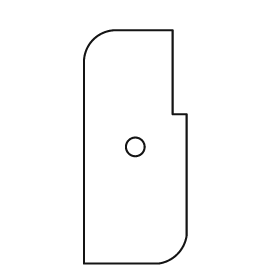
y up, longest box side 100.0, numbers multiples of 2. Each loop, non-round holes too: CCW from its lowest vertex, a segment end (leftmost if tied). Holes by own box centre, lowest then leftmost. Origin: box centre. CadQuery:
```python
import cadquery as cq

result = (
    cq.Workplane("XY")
    .moveTo(-22.0, -50.0)
    .lineTo(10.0, -50.0)
    .threePointArc((18.0, -46.0), (22.0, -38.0))
    .lineTo(22.0, 14.0)
    .lineTo(16.0, 14.0)
    .lineTo(16.0, 50.0)
    .lineTo(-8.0, 50.0)
    .threePointArc((-18.0, 46.0), (-22.0, 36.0))
    .close()
    .moveTo(0.0, 0.0)
    .circle(4.0)
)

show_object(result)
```